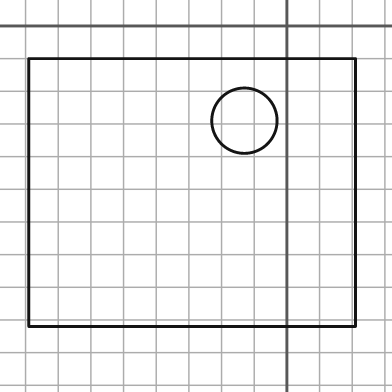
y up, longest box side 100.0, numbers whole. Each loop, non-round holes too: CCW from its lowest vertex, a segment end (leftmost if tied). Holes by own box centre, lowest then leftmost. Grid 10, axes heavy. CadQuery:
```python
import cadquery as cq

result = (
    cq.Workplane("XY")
    .moveTo(-79.0, -92.0)
    .lineTo(21.0, -92.0)
    .lineTo(21.0, -10.0)
    .lineTo(-79.0, -10.0)
    .close()
    .moveTo(-13.0, -29.0)
    .circle(10.0)
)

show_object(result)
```